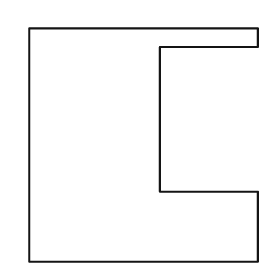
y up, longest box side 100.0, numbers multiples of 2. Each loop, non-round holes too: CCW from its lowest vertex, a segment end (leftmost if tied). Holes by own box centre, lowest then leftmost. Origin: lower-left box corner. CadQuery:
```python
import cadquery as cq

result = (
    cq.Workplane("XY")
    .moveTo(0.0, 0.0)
    .lineTo(98.0, 0.0)
    .lineTo(98.0, 30.0)
    .lineTo(56.0, 30.0)
    .lineTo(56.0, 92.0)
    .lineTo(98.0, 92.0)
    .lineTo(98.0, 100.0)
    .lineTo(0.0, 100.0)
    .close()
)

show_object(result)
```